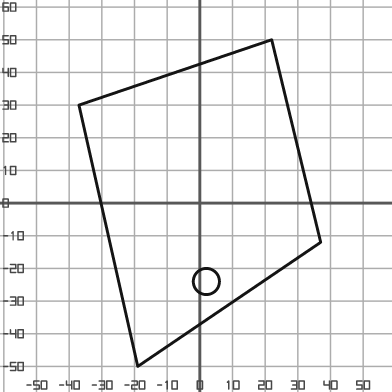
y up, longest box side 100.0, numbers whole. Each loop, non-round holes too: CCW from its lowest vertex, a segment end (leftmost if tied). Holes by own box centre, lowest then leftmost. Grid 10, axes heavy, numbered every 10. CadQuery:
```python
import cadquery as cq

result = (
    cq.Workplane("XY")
    .moveTo(-19.0, -50.0)
    .lineTo(37.0, -12.0)
    .lineTo(22.0, 50.0)
    .lineTo(-37.0, 30.0)
    .close()
    .moveTo(2.0, -24.0)
    .circle(4.0)
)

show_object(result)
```